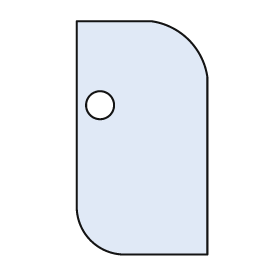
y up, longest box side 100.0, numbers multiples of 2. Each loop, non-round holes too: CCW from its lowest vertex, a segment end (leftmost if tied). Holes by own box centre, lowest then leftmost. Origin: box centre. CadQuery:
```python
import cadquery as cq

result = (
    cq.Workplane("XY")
    .moveTo(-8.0, -50.0)
    .lineTo(28.0, -50.0)
    .lineTo(28.0, 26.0)
    .threePointArc((20.0, 42.0), (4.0, 50.0))
    .lineTo(-28.0, 50.0)
    .lineTo(-28.0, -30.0)
    .threePointArc((-22.0, -44.0), (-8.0, -50.0))
    .close()
    .moveTo(-18.0, 14.0)
    .circle(6.0)
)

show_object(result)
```